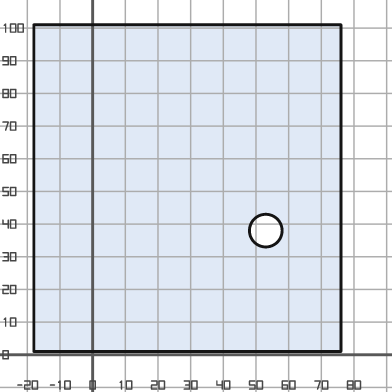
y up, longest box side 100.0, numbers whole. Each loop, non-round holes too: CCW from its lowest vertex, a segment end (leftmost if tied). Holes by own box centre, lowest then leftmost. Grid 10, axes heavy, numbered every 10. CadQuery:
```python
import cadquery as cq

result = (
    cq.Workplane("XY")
    .moveTo(-18.0, 1.0)
    .lineTo(76.0, 1.0)
    .lineTo(76.0, 101.0)
    .lineTo(-18.0, 101.0)
    .close()
    .moveTo(53.0, 38.0)
    .circle(5.0)
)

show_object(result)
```